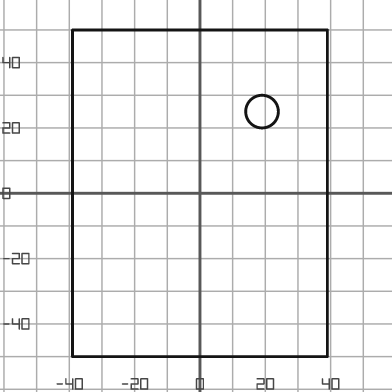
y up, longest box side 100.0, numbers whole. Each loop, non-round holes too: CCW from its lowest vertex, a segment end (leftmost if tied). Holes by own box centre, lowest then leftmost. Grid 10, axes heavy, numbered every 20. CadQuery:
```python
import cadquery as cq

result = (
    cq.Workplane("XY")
    .moveTo(-39.0, -50.0)
    .lineTo(39.0, -50.0)
    .lineTo(39.0, 50.0)
    .lineTo(-39.0, 50.0)
    .close()
    .moveTo(19.0, 25.0)
    .circle(5.0)
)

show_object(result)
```